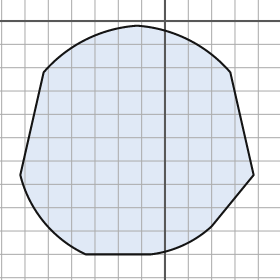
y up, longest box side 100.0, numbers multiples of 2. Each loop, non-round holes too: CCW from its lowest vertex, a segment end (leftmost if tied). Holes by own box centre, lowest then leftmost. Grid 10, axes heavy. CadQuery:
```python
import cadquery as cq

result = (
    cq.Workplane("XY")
    .moveTo(-34.0, -100.0)
    .lineTo(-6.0, -100.0)
    .threePointArc((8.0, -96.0), (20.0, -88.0))
    .lineTo(38.0, -66.0)
    .lineTo(28.0, -22.0)
    .threePointArc((10.0, -8.0), (-12.0, -2.0))
    .threePointArc((-34.0, -8.0), (-52.0, -22.0))
    .lineTo(-62.0, -66.0)
    .threePointArc((-52.0, -86.0), (-34.0, -100.0))
    .close()
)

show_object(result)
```